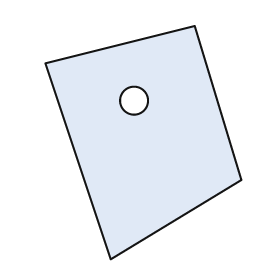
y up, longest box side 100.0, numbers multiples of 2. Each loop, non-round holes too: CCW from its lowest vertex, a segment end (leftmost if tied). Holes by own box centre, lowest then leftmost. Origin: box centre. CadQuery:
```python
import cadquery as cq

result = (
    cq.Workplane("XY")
    .moveTo(-14.0, -50.0)
    .lineTo(42.0, -16.0)
    .lineTo(22.0, 50.0)
    .lineTo(-42.0, 34.0)
    .close()
    .moveTo(-4.0, 18.0)
    .circle(6.0)
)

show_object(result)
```